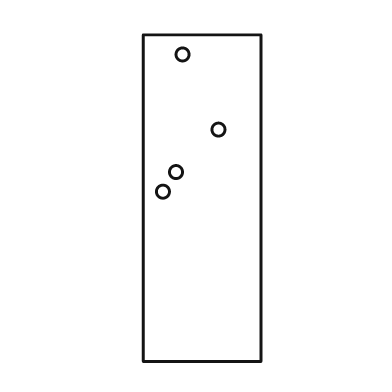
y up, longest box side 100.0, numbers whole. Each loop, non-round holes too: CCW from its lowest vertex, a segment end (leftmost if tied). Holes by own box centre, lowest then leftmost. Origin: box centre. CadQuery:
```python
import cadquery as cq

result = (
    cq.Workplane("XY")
    .moveTo(-18.0, -50.0)
    .lineTo(18.0, -50.0)
    .lineTo(18.0, 50.0)
    .lineTo(-18.0, 50.0)
    .close()
    .moveTo(-12.0, 2.0)
    .circle(2.0)
    .moveTo(-8.0, 8.0)
    .circle(2.0)
    .moveTo(5.0, 21.0)
    .circle(2.0)
    .moveTo(-6.0, 44.0)
    .circle(2.0)
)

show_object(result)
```